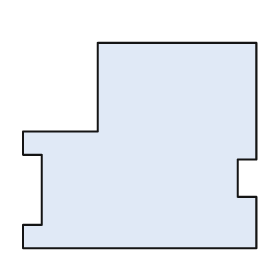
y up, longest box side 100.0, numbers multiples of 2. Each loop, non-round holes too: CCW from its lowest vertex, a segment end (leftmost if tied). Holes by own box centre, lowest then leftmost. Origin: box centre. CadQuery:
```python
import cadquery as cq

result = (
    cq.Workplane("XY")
    .moveTo(-50.0, -44.0)
    .lineTo(50.0, -44.0)
    .lineTo(50.0, -22.0)
    .lineTo(42.0, -22.0)
    .lineTo(42.0, -6.0)
    .lineTo(50.0, -6.0)
    .lineTo(50.0, 44.0)
    .lineTo(-18.0, 44.0)
    .lineTo(-18.0, 6.0)
    .lineTo(-50.0, 6.0)
    .lineTo(-50.0, -4.0)
    .lineTo(-42.0, -4.0)
    .lineTo(-42.0, -34.0)
    .lineTo(-50.0, -34.0)
    .close()
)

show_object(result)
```